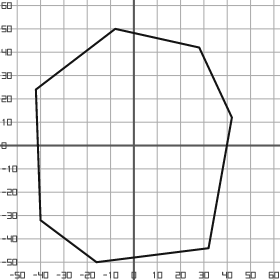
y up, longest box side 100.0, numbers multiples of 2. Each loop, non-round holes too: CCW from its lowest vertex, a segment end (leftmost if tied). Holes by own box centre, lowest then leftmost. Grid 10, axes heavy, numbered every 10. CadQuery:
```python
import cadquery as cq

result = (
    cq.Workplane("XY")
    .moveTo(-16.0, -50.0)
    .lineTo(32.0, -44.0)
    .lineTo(42.0, 12.0)
    .lineTo(28.0, 42.0)
    .lineTo(-8.0, 50.0)
    .lineTo(-42.0, 24.0)
    .lineTo(-40.0, -32.0)
    .close()
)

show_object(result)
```